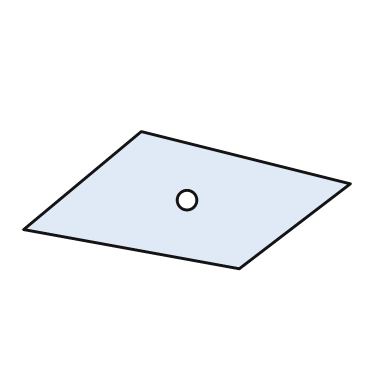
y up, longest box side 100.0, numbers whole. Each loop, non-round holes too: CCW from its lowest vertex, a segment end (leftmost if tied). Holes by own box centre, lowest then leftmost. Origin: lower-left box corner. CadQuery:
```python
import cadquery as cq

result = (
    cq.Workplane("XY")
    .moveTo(66.0, 0.0)
    .lineTo(100.0, 26.0)
    .lineTo(36.0, 42.0)
    .lineTo(0.0, 12.0)
    .close()
    .moveTo(50.0, 21.0)
    .circle(3.0)
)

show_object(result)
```